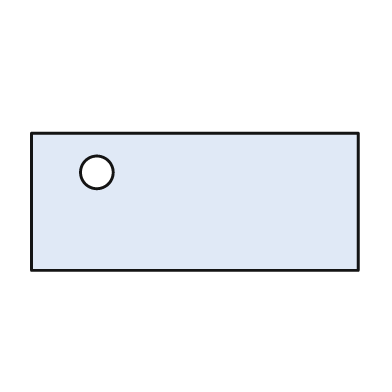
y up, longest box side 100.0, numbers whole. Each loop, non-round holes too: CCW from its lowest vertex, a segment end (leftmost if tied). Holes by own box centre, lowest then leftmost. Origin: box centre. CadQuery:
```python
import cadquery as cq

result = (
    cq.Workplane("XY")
    .moveTo(-50.0, -21.0)
    .lineTo(50.0, -21.0)
    .lineTo(50.0, 21.0)
    .lineTo(-50.0, 21.0)
    .close()
    .moveTo(-30.0, 9.0)
    .circle(5.0)
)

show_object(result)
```